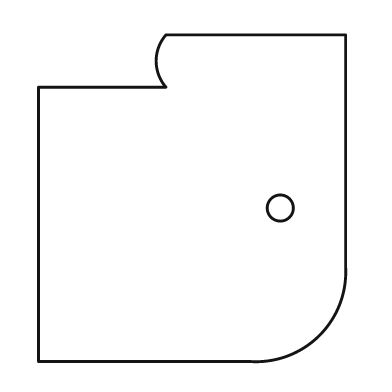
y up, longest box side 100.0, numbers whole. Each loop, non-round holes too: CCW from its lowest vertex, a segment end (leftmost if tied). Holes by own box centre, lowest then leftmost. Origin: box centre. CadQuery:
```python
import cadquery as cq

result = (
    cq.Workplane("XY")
    .moveTo(-47.0, -50.0)
    .lineTo(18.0, -50.0)
    .threePointArc((39.0, -42.0), (47.0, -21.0))
    .lineTo(47.0, 50.0)
    .lineTo(-8.0, 50.0)
    .threePointArc((-11.0, 42.0), (-8.0, 34.0))
    .lineTo(-47.0, 34.0)
    .close()
    .moveTo(27.0, -3.0)
    .circle(4.0)
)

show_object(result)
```